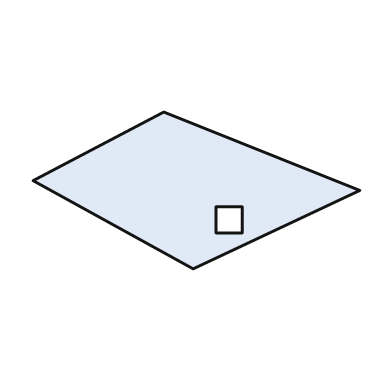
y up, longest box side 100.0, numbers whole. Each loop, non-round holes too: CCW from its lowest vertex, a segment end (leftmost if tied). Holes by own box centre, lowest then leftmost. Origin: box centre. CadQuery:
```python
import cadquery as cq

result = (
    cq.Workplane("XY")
    .moveTo(-1.0, -24.0)
    .lineTo(50.0, 0.0)
    .lineTo(-10.0, 24.0)
    .lineTo(-50.0, 3.0)
    .close()
    .moveTo(6.0, -13.0)
    .lineTo(14.0, -13.0)
    .lineTo(14.0, -5.0)
    .lineTo(6.0, -5.0)
    .close()
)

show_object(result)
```